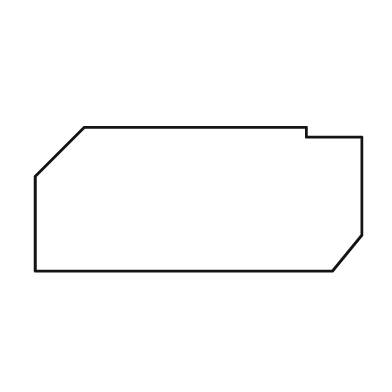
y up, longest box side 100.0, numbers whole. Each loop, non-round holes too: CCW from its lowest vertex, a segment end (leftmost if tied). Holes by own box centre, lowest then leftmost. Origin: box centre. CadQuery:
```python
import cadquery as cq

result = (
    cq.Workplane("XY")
    .moveTo(-50.0, -22.0)
    .lineTo(41.0, -22.0)
    .lineTo(50.0, -11.0)
    .lineTo(50.0, 19.0)
    .lineTo(33.0, 19.0)
    .lineTo(33.0, 22.0)
    .lineTo(-35.0, 22.0)
    .lineTo(-50.0, 7.0)
    .close()
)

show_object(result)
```